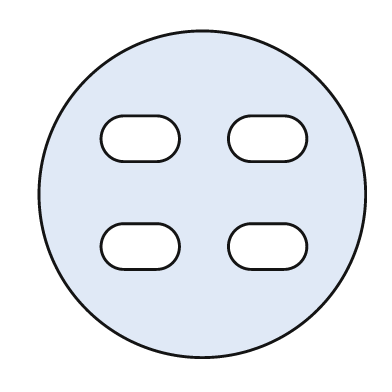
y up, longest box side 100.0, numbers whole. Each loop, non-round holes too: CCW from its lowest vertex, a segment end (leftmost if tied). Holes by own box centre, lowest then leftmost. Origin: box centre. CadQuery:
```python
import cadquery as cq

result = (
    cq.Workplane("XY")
    .moveTo(0.0, 0.0)
    .circle(50.0)
    .moveTo(-24.0, -23.0)
    .lineTo(-14.0, -23.0)
    .threePointArc((-7.0, -16.0), (-14.0, -9.0))
    .lineTo(-24.0, -9.0)
    .threePointArc((-31.0, -16.0), (-24.0, -23.0))
    .close()
    .moveTo(15.0, -23.0)
    .lineTo(25.0, -23.0)
    .threePointArc((32.0, -16.0), (25.0, -9.0))
    .lineTo(15.0, -9.0)
    .threePointArc((8.0, -16.0), (15.0, -23.0))
    .close()
    .moveTo(-24.0, 10.0)
    .lineTo(-14.0, 10.0)
    .threePointArc((-7.0, 17.0), (-14.0, 24.0))
    .lineTo(-24.0, 24.0)
    .threePointArc((-31.0, 17.0), (-24.0, 10.0))
    .close()
    .moveTo(15.0, 10.0)
    .lineTo(25.0, 10.0)
    .threePointArc((32.0, 17.0), (25.0, 24.0))
    .lineTo(15.0, 24.0)
    .threePointArc((8.0, 17.0), (15.0, 10.0))
    .close()
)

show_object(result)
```